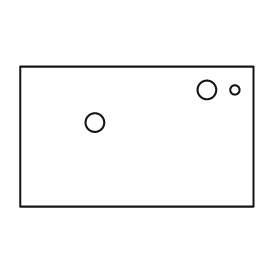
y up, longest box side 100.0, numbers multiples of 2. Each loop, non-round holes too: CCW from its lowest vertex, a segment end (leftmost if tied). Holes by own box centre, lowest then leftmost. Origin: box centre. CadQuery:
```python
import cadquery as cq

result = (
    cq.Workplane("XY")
    .moveTo(-50.0, -30.0)
    .lineTo(50.0, -30.0)
    .lineTo(50.0, 30.0)
    .lineTo(-50.0, 30.0)
    .close()
    .moveTo(-18.0, 6.0)
    .circle(4.0)
    .moveTo(30.0, 20.0)
    .circle(4.0)
    .moveTo(42.0, 20.0)
    .circle(2.0)
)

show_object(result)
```